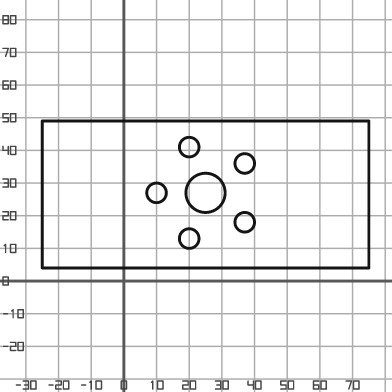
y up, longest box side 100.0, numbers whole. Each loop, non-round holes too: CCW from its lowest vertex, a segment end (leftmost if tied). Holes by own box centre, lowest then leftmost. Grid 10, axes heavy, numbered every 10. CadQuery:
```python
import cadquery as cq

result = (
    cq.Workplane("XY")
    .moveTo(-25.0, 4.0)
    .lineTo(75.0, 4.0)
    .lineTo(75.0, 49.0)
    .lineTo(-25.0, 49.0)
    .close()
    .moveTo(20.0, 13.0)
    .circle(3.0)
    .moveTo(37.0, 18.0)
    .circle(3.0)
    .moveTo(10.0, 27.0)
    .circle(3.0)
    .moveTo(25.0, 27.0)
    .circle(6.0)
    .moveTo(37.0, 36.0)
    .circle(3.0)
    .moveTo(20.0, 41.0)
    .circle(3.0)
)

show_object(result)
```